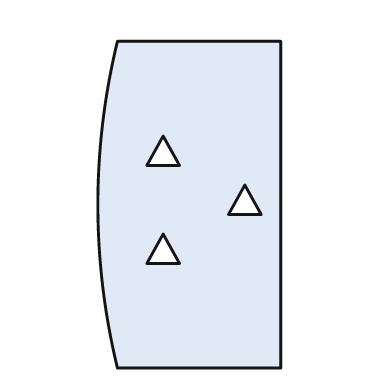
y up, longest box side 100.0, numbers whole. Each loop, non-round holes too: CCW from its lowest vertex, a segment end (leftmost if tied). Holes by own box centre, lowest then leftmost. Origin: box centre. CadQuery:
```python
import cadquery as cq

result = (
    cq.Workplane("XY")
    .moveTo(-22.0, -50.0)
    .lineTo(28.0, -50.0)
    .lineTo(28.0, 50.0)
    .lineTo(-22.0, 50.0)
    .threePointArc((-28.0, 0.0), (-22.0, -50.0))
    .close()
    .moveTo(-13.0, -18.0)
    .lineTo(-3.0, -18.0)
    .lineTo(-8.0, -9.0)
    .close()
    .moveTo(12.0, -3.0)
    .lineTo(22.0, -3.0)
    .lineTo(17.0, 6.0)
    .close()
    .moveTo(-13.0, 12.0)
    .lineTo(-3.0, 12.0)
    .lineTo(-8.0, 21.0)
    .close()
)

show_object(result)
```